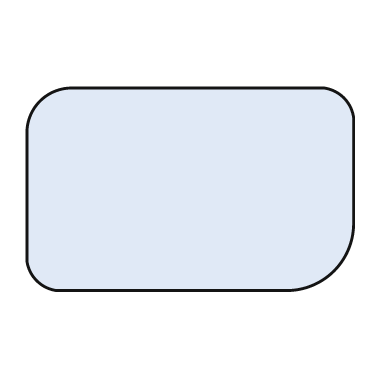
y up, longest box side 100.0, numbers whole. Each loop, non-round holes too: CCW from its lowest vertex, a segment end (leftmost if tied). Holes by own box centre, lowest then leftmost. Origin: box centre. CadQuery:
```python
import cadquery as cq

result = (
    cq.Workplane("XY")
    .moveTo(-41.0, -31.0)
    .lineTo(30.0, -31.0)
    .threePointArc((44.0, -25.0), (50.0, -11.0))
    .lineTo(50.0, 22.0)
    .threePointArc((47.0, 28.0), (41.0, 31.0))
    .lineTo(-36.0, 31.0)
    .threePointArc((-46.0, 27.0), (-50.0, 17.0))
    .lineTo(-50.0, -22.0)
    .threePointArc((-47.0, -28.0), (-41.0, -31.0))
    .close()
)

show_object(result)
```